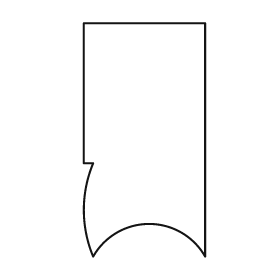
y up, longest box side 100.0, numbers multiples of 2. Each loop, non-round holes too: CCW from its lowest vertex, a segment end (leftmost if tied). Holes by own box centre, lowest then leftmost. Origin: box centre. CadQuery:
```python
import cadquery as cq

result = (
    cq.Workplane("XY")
    .moveTo(-22.0, -50.0)
    .threePointArc((2.0, -36.0), (26.0, -50.0))
    .lineTo(26.0, 50.0)
    .lineTo(-26.0, 50.0)
    .lineTo(-26.0, -10.0)
    .lineTo(-22.0, -10.0)
    .threePointArc((-26.0, -30.0), (-22.0, -50.0))
    .close()
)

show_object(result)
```